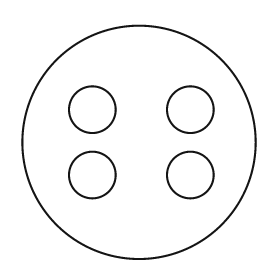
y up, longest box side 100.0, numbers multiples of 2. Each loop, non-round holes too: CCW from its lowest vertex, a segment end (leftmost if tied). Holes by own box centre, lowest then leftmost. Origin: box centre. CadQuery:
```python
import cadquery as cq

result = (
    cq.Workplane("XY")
    .moveTo(0.0, 0.0)
    .circle(50.0)
    .moveTo(-20.0, -14.0)
    .circle(10.0)
    .moveTo(22.0, -14.0)
    .circle(10.0)
    .moveTo(-20.0, 14.0)
    .circle(10.0)
    .moveTo(22.0, 14.0)
    .circle(10.0)
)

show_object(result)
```